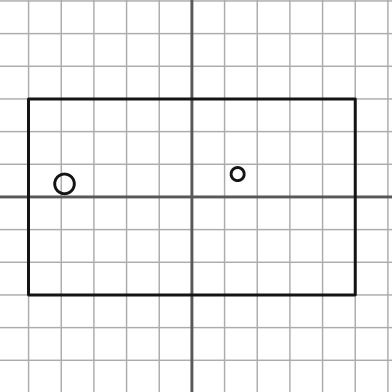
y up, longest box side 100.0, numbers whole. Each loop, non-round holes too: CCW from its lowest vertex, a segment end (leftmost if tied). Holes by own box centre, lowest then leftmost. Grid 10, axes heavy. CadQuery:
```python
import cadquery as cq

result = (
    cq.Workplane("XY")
    .moveTo(-50.0, -30.0)
    .lineTo(50.0, -30.0)
    .lineTo(50.0, 30.0)
    .lineTo(-50.0, 30.0)
    .close()
    .moveTo(-39.0, 4.0)
    .circle(3.0)
    .moveTo(14.0, 7.0)
    .circle(2.0)
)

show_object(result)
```